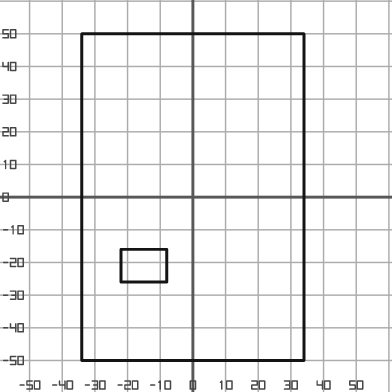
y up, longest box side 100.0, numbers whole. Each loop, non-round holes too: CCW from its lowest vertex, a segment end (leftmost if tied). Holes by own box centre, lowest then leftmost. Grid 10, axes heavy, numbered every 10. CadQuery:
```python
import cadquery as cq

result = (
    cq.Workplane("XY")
    .moveTo(-34.0, -50.0)
    .lineTo(34.0, -50.0)
    .lineTo(34.0, 50.0)
    .lineTo(-34.0, 50.0)
    .close()
    .moveTo(-22.0, -26.0)
    .lineTo(-8.0, -26.0)
    .lineTo(-8.0, -16.0)
    .lineTo(-22.0, -16.0)
    .close()
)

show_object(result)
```